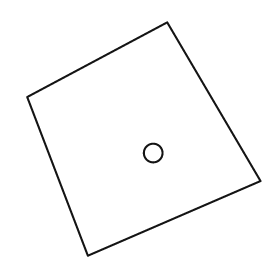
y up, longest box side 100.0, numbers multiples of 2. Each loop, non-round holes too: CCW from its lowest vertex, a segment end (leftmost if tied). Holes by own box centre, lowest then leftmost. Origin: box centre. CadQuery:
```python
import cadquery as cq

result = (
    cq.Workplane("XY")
    .moveTo(-24.0, -50.0)
    .lineTo(50.0, -18.0)
    .lineTo(10.0, 50.0)
    .lineTo(-50.0, 18.0)
    .close()
    .moveTo(4.0, -6.0)
    .circle(4.0)
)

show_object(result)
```